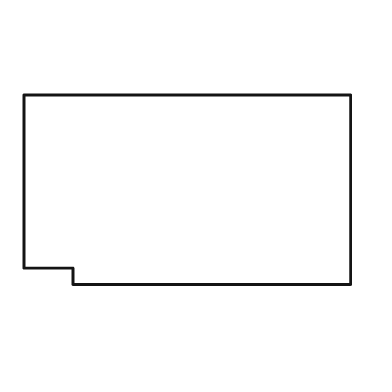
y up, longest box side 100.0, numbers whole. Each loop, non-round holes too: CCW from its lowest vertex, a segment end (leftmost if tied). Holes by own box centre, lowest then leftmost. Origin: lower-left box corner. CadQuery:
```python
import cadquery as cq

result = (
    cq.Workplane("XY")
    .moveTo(15.0, 0.0)
    .lineTo(100.0, 0.0)
    .lineTo(100.0, 58.0)
    .lineTo(0.0, 58.0)
    .lineTo(0.0, 5.0)
    .lineTo(15.0, 5.0)
    .close()
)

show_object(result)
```